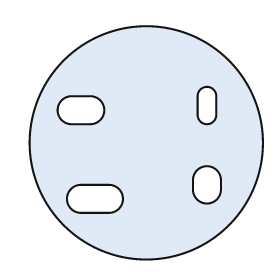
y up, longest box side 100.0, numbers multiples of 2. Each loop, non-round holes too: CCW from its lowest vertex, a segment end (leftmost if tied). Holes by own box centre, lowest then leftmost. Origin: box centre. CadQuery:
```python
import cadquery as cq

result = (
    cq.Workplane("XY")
    .moveTo(0.0, 0.0)
    .circle(50.0)
    .moveTo(-28.0, -30.0)
    .lineTo(-16.0, -30.0)
    .threePointArc((-10.0, -24.0), (-16.0, -18.0))
    .lineTo(-28.0, -18.0)
    .threePointArc((-34.0, -24.0), (-28.0, -30.0))
    .close()
    .moveTo(20.0, -20.0)
    .threePointArc((26.0, -26.0), (32.0, -20.0))
    .lineTo(32.0, -16.0)
    .threePointArc((26.0, -10.0), (20.0, -16.0))
    .close()
    .moveTo(-32.0, 8.0)
    .lineTo(-24.0, 8.0)
    .threePointArc((-18.0, 14.0), (-24.0, 20.0))
    .lineTo(-32.0, 20.0)
    .threePointArc((-38.0, 14.0), (-32.0, 8.0))
    .close()
    .moveTo(22.0, 12.0)
    .threePointArc((26.0, 8.0), (30.0, 12.0))
    .lineTo(30.0, 20.0)
    .threePointArc((26.0, 24.0), (22.0, 20.0))
    .close()
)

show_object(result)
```